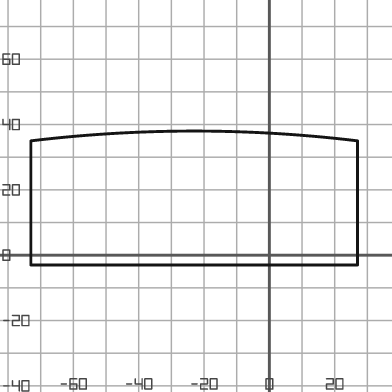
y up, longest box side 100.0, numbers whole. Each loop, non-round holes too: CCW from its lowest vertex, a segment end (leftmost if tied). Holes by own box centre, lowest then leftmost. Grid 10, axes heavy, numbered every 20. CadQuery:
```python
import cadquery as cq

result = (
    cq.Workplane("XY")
    .moveTo(-73.0, -3.0)
    .lineTo(27.0, -3.0)
    .lineTo(27.0, 35.0)
    .threePointArc((-23.0, 38.0), (-73.0, 35.0))
    .close()
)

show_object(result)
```